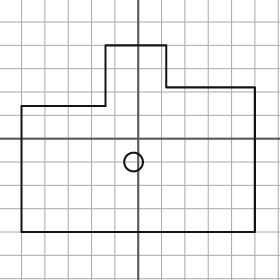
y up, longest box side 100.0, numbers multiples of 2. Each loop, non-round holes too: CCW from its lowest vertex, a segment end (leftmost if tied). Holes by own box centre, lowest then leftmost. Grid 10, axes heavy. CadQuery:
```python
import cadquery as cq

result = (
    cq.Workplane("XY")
    .moveTo(-50.0, -40.0)
    .lineTo(50.0, -40.0)
    .lineTo(50.0, 22.0)
    .lineTo(12.0, 22.0)
    .lineTo(12.0, 40.0)
    .lineTo(-14.0, 40.0)
    .lineTo(-14.0, 14.0)
    .lineTo(-50.0, 14.0)
    .close()
    .moveTo(-2.0, -10.0)
    .circle(4.0)
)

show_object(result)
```